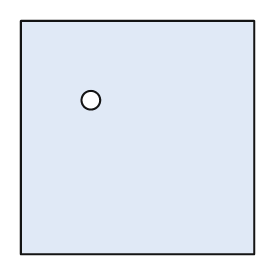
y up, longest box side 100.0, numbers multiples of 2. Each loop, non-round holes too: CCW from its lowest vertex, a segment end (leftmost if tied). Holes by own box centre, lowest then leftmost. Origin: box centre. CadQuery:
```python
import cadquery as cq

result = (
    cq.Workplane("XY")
    .moveTo(-50.0, -50.0)
    .lineTo(50.0, -50.0)
    .lineTo(50.0, 50.0)
    .lineTo(-50.0, 50.0)
    .close()
    .moveTo(-20.0, 16.0)
    .circle(4.0)
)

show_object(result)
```